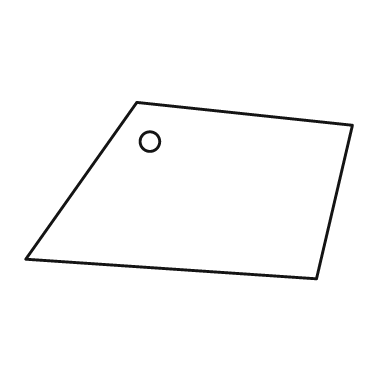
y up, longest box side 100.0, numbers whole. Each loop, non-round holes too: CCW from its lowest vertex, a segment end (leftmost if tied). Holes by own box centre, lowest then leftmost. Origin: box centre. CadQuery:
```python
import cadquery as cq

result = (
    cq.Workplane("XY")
    .moveTo(39.0, -27.0)
    .lineTo(50.0, 20.0)
    .lineTo(-16.0, 27.0)
    .lineTo(-50.0, -21.0)
    .close()
    .moveTo(-12.0, 15.0)
    .circle(3.0)
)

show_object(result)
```